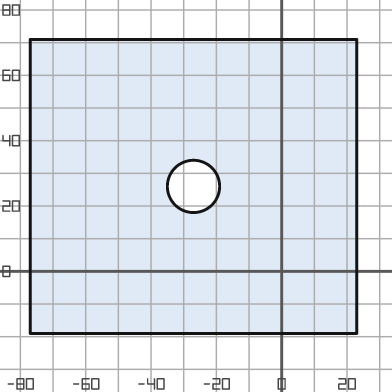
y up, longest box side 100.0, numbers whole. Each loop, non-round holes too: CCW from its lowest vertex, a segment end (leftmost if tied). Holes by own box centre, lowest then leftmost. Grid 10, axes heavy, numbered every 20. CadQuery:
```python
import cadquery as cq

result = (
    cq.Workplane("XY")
    .moveTo(-77.0, -19.0)
    .lineTo(23.0, -19.0)
    .lineTo(23.0, 71.0)
    .lineTo(-77.0, 71.0)
    .close()
    .moveTo(-27.0, 26.0)
    .circle(8.0)
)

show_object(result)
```